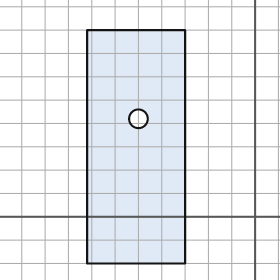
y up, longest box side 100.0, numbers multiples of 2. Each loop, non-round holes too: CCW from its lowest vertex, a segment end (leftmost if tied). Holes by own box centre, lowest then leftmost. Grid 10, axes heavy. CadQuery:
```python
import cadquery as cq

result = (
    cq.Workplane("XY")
    .moveTo(-72.0, -20.0)
    .lineTo(-30.0, -20.0)
    .lineTo(-30.0, 80.0)
    .lineTo(-72.0, 80.0)
    .close()
    .moveTo(-50.0, 42.0)
    .circle(4.0)
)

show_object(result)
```